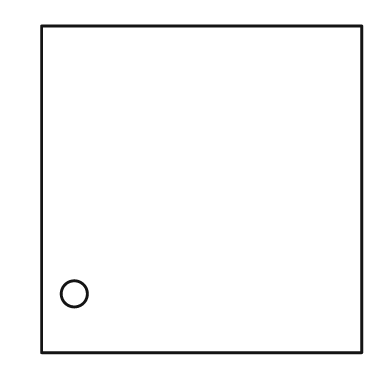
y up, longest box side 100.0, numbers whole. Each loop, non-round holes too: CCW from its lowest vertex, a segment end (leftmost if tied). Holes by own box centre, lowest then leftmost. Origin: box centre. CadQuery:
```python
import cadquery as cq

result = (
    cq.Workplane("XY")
    .moveTo(-49.0, -50.0)
    .lineTo(49.0, -50.0)
    .lineTo(49.0, 50.0)
    .lineTo(-49.0, 50.0)
    .close()
    .moveTo(-39.0, -32.0)
    .circle(4.0)
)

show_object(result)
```